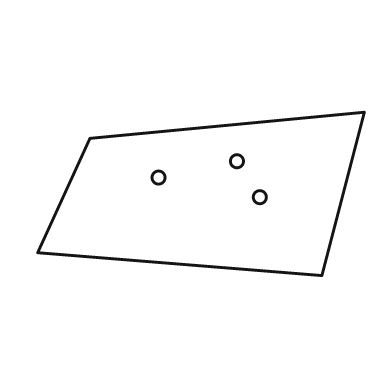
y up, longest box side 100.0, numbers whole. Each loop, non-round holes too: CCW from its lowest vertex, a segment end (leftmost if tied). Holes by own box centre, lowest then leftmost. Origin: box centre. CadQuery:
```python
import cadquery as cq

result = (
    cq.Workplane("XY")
    .moveTo(37.0, -25.0)
    .lineTo(50.0, 25.0)
    .lineTo(-34.0, 17.0)
    .lineTo(-50.0, -18.0)
    .close()
    .moveTo(18.0, -1.0)
    .circle(2.0)
    .moveTo(-13.0, 5.0)
    .circle(2.0)
    .moveTo(11.0, 10.0)
    .circle(2.0)
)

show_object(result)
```